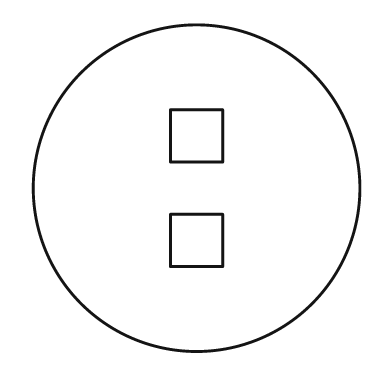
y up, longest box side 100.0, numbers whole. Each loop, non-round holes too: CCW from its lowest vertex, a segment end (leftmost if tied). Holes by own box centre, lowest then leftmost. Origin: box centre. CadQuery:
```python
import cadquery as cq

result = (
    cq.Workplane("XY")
    .moveTo(0.0, 0.0)
    .circle(50.0)
    .moveTo(-8.0, -24.0)
    .lineTo(8.0, -24.0)
    .lineTo(8.0, -8.0)
    .lineTo(-8.0, -8.0)
    .close()
    .moveTo(-8.0, 8.0)
    .lineTo(8.0, 8.0)
    .lineTo(8.0, 24.0)
    .lineTo(-8.0, 24.0)
    .close()
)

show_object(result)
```